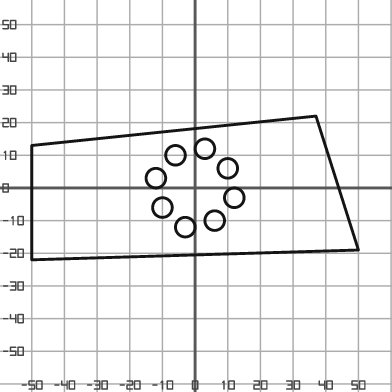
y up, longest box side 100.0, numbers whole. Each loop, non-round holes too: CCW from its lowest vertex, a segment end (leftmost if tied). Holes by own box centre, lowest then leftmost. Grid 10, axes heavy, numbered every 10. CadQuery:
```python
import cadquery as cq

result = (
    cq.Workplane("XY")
    .moveTo(-50.0, -22.0)
    .lineTo(50.0, -19.0)
    .lineTo(37.0, 22.0)
    .lineTo(-50.0, 13.0)
    .close()
    .moveTo(-3.0, -12.0)
    .circle(3.0)
    .moveTo(6.0, -10.0)
    .circle(3.0)
    .moveTo(-10.0, -6.0)
    .circle(3.0)
    .moveTo(12.0, -3.0)
    .circle(3.0)
    .moveTo(-12.0, 3.0)
    .circle(3.0)
    .moveTo(10.0, 6.0)
    .circle(3.0)
    .moveTo(-6.0, 10.0)
    .circle(3.0)
    .moveTo(3.0, 12.0)
    .circle(3.0)
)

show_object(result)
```